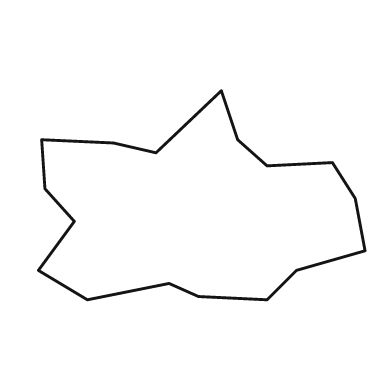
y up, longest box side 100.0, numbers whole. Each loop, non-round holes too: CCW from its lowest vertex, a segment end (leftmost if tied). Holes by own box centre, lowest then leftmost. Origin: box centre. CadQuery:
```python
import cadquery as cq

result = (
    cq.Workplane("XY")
    .moveTo(-35.0, -32.0)
    .lineTo(-10.0, -27.0)
    .lineTo(-1.0, -31.0)
    .lineTo(20.0, -32.0)
    .lineTo(29.0, -23.0)
    .lineTo(50.0, -17.0)
    .lineTo(47.0, -1.0)
    .lineTo(40.0, 10.0)
    .lineTo(20.0, 9.0)
    .lineTo(11.0, 17.0)
    .lineTo(6.0, 32.0)
    .lineTo(-14.0, 13.0)
    .lineTo(-27.0, 16.0)
    .lineTo(-49.0, 17.0)
    .lineTo(-48.0, 2.0)
    .lineTo(-39.0, -8.0)
    .lineTo(-50.0, -23.0)
    .close()
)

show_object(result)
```